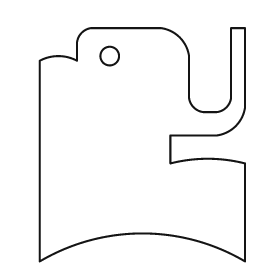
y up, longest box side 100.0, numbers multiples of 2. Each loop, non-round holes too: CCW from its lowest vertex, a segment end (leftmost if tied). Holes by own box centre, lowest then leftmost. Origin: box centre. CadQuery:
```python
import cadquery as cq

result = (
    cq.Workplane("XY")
    .moveTo(-44.0, -50.0)
    .threePointArc((0.0, -38.0), (44.0, -50.0))
    .lineTo(44.0, -8.0)
    .threePointArc((28.0, -6.0), (12.0, -8.0))
    .lineTo(12.0, 4.0)
    .lineTo(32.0, 4.0)
    .threePointArc((40.0, 8.0), (44.0, 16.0))
    .lineTo(44.0, 50.0)
    .lineTo(38.0, 50.0)
    .lineTo(38.0, 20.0)
    .threePointArc((36.0, 16.0), (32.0, 14.0))
    .lineTo(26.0, 14.0)
    .threePointArc((22.0, 16.0), (20.0, 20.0))
    .lineTo(20.0, 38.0)
    .threePointArc((16.0, 46.0), (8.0, 50.0))
    .lineTo(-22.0, 50.0)
    .threePointArc((-26.0, 48.0), (-28.0, 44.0))
    .lineTo(-28.0, 36.0)
    .threePointArc((-36.0, 38.0), (-44.0, 36.0))
    .close()
    .moveTo(-14.0, 38.0)
    .circle(4.0)
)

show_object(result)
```